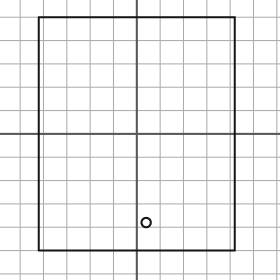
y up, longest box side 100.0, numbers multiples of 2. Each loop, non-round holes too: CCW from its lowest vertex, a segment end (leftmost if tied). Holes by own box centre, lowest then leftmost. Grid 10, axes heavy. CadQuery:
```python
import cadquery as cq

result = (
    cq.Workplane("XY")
    .moveTo(-42.0, -50.0)
    .lineTo(42.0, -50.0)
    .lineTo(42.0, 50.0)
    .lineTo(-42.0, 50.0)
    .close()
    .moveTo(4.0, -38.0)
    .circle(2.0)
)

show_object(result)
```